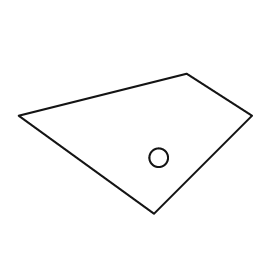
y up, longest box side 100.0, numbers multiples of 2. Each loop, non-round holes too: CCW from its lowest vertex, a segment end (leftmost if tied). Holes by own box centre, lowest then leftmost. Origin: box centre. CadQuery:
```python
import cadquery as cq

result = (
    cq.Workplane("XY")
    .moveTo(8.0, -30.0)
    .lineTo(50.0, 12.0)
    .lineTo(22.0, 30.0)
    .lineTo(-50.0, 12.0)
    .close()
    .moveTo(10.0, -6.0)
    .circle(4.0)
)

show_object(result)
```